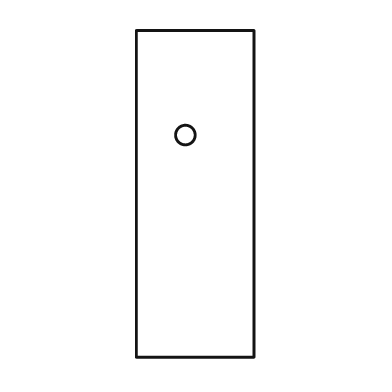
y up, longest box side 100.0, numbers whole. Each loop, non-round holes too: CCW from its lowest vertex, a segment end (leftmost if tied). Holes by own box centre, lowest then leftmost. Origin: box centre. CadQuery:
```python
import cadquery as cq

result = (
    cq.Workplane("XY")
    .moveTo(-18.0, -50.0)
    .lineTo(18.0, -50.0)
    .lineTo(18.0, 50.0)
    .lineTo(-18.0, 50.0)
    .close()
    .moveTo(-3.0, 18.0)
    .circle(3.0)
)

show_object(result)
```